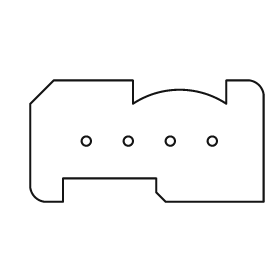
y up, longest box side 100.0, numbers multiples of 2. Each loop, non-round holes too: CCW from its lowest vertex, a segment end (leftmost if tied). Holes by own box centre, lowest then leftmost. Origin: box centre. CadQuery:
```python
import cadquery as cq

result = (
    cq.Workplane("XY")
    .moveTo(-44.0, -26.0)
    .lineTo(-36.0, -26.0)
    .lineTo(-36.0, -16.0)
    .lineTo(4.0, -16.0)
    .lineTo(4.0, -22.0)
    .lineTo(8.0, -26.0)
    .lineTo(50.0, -26.0)
    .lineTo(50.0, 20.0)
    .threePointArc((48.0, 24.0), (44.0, 26.0))
    .lineTo(34.0, 26.0)
    .lineTo(34.0, 16.0)
    .threePointArc((14.0, 22.0), (-6.0, 16.0))
    .lineTo(-6.0, 26.0)
    .lineTo(-40.0, 26.0)
    .lineTo(-50.0, 16.0)
    .lineTo(-50.0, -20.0)
    .threePointArc((-48.0, -24.0), (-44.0, -26.0))
    .close()
    .moveTo(-26.0, 0.0)
    .circle(2.0)
    .moveTo(-8.0, 0.0)
    .circle(2.0)
    .moveTo(10.0, 0.0)
    .circle(2.0)
    .moveTo(28.0, 0.0)
    .circle(2.0)
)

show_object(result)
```